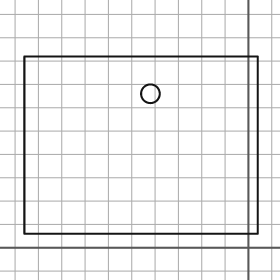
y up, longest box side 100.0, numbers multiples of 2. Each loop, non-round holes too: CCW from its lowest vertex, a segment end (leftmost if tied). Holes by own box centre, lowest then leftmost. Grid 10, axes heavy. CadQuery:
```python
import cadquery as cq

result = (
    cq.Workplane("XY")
    .moveTo(-96.0, 6.0)
    .lineTo(4.0, 6.0)
    .lineTo(4.0, 82.0)
    .lineTo(-96.0, 82.0)
    .close()
    .moveTo(-42.0, 66.0)
    .circle(4.0)
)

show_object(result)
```